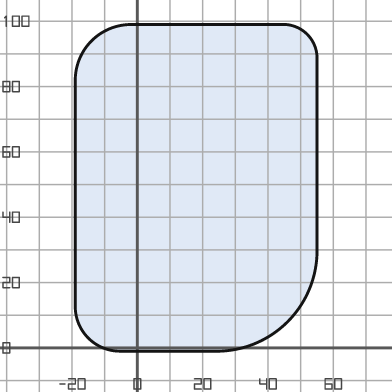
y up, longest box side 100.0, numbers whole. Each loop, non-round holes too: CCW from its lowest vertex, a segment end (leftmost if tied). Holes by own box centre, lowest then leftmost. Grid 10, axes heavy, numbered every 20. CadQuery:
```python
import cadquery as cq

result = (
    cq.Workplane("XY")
    .moveTo(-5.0, -1.0)
    .lineTo(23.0, -1.0)
    .threePointArc((46.0, 8.0), (55.0, 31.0))
    .lineTo(55.0, 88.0)
    .threePointArc((52.0, 96.0), (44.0, 99.0))
    .lineTo(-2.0, 99.0)
    .threePointArc((-14.0, 94.0), (-19.0, 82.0))
    .lineTo(-19.0, 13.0)
    .threePointArc((-15.0, 3.0), (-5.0, -1.0))
    .close()
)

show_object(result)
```